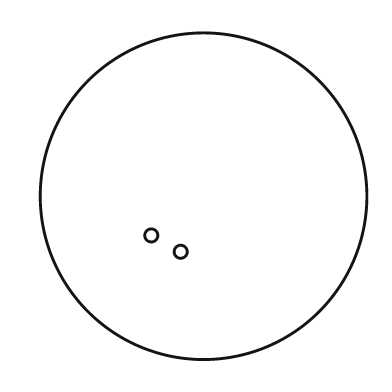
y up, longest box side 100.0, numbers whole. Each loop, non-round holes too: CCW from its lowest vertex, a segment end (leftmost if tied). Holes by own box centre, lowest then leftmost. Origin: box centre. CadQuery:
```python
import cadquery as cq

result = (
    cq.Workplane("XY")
    .moveTo(0.0, 0.0)
    .circle(50.0)
    .moveTo(-7.0, -17.0)
    .circle(2.0)
    .moveTo(-16.0, -12.0)
    .circle(2.0)
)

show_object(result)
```